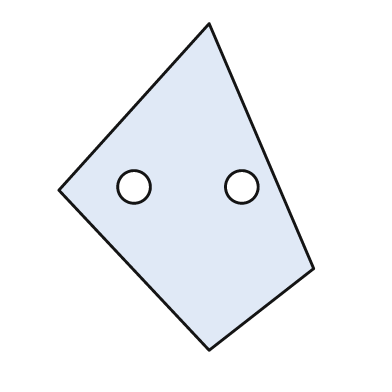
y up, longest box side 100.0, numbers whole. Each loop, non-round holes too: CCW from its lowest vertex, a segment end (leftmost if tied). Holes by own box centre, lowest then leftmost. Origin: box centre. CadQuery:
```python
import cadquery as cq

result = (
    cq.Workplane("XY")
    .moveTo(7.0, -50.0)
    .lineTo(39.0, -25.0)
    .lineTo(7.0, 50.0)
    .lineTo(-39.0, -1.0)
    .close()
    .moveTo(-16.0, 0.0)
    .circle(5.0)
    .moveTo(17.0, 0.0)
    .circle(5.0)
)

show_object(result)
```